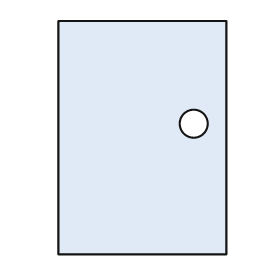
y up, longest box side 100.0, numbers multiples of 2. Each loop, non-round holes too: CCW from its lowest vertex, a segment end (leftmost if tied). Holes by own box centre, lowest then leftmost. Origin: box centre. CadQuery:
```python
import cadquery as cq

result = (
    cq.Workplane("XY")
    .moveTo(-36.0, -50.0)
    .lineTo(36.0, -50.0)
    .lineTo(36.0, 50.0)
    .lineTo(-36.0, 50.0)
    .close()
    .moveTo(22.0, 6.0)
    .circle(6.0)
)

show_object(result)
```